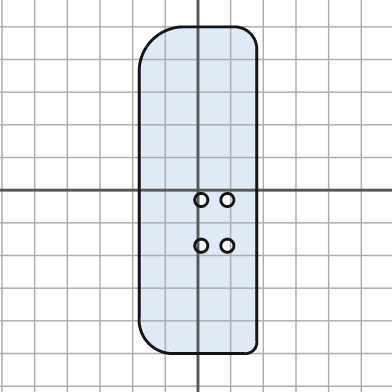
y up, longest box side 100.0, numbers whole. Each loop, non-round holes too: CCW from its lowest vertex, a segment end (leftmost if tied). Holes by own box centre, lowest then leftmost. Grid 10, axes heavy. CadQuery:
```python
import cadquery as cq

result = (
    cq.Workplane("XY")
    .moveTo(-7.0, -50.0)
    .lineTo(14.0, -50.0)
    .threePointArc((17.0, -49.0), (18.0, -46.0))
    .lineTo(18.0, 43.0)
    .threePointArc((16.0, 48.0), (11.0, 50.0))
    .lineTo(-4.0, 50.0)
    .threePointArc((-14.0, 46.0), (-18.0, 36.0))
    .lineTo(-18.0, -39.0)
    .threePointArc((-15.0, -47.0), (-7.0, -50.0))
    .close()
    .moveTo(1.0, -17.0)
    .circle(2.0)
    .moveTo(9.0, -17.0)
    .circle(2.0)
    .moveTo(1.0, -3.0)
    .circle(2.0)
    .moveTo(9.0, -3.0)
    .circle(2.0)
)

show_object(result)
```